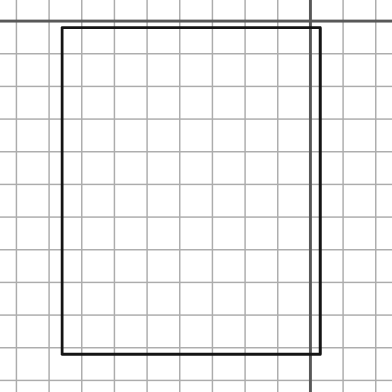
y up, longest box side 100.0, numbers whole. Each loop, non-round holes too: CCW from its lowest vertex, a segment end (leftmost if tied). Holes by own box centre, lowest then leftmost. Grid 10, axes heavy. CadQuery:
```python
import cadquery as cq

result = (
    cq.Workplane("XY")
    .moveTo(-76.0, -102.0)
    .lineTo(3.0, -102.0)
    .lineTo(3.0, -2.0)
    .lineTo(-76.0, -2.0)
    .close()
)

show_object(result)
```